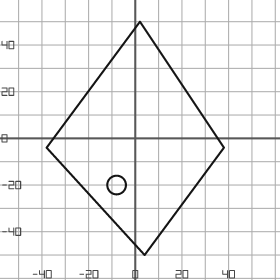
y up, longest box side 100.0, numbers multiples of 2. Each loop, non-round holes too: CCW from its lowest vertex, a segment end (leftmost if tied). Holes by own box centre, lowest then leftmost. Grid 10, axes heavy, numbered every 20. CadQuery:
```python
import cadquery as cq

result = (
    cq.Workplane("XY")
    .moveTo(4.0, -50.0)
    .lineTo(38.0, -4.0)
    .lineTo(2.0, 50.0)
    .lineTo(-38.0, -4.0)
    .close()
    .moveTo(-8.0, -20.0)
    .circle(4.0)
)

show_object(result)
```